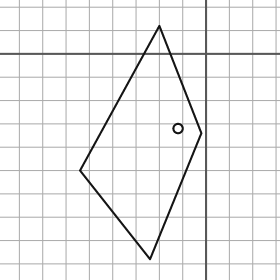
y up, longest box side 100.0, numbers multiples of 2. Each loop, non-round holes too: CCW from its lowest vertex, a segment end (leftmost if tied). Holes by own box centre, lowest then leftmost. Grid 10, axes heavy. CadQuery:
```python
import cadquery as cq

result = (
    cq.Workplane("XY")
    .moveTo(-24.0, -88.0)
    .lineTo(-2.0, -34.0)
    .lineTo(-20.0, 12.0)
    .lineTo(-54.0, -50.0)
    .close()
    .moveTo(-12.0, -32.0)
    .circle(2.0)
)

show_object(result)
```